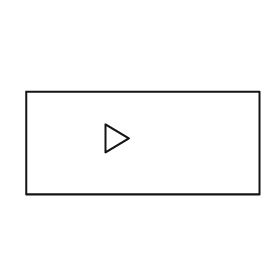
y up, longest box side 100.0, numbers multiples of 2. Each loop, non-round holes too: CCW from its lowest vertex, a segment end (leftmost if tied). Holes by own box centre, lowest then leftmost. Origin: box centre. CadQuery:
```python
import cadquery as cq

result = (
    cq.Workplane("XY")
    .moveTo(-50.0, -22.0)
    .lineTo(50.0, -22.0)
    .lineTo(50.0, 22.0)
    .lineTo(-50.0, 22.0)
    .close()
    .moveTo(-16.0, -4.0)
    .lineTo(-6.0, 2.0)
    .lineTo(-16.0, 8.0)
    .close()
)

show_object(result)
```